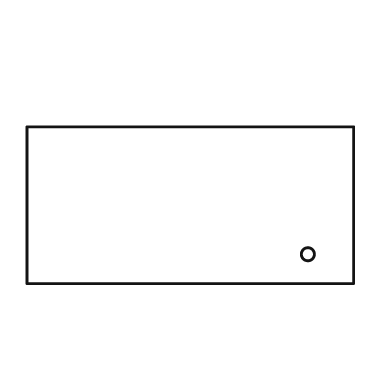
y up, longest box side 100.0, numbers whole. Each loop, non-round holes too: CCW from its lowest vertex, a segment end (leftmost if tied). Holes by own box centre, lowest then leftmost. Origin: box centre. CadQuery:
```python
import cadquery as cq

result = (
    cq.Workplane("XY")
    .moveTo(-50.0, -24.0)
    .lineTo(50.0, -24.0)
    .lineTo(50.0, 24.0)
    .lineTo(-50.0, 24.0)
    .close()
    .moveTo(36.0, -15.0)
    .circle(2.0)
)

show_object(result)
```